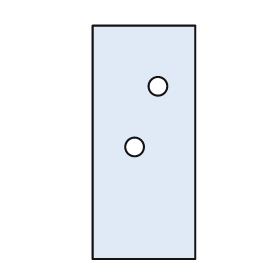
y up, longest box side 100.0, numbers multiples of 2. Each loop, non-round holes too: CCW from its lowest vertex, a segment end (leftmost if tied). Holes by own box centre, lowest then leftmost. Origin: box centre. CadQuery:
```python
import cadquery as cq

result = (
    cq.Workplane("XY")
    .moveTo(-22.0, -50.0)
    .lineTo(22.0, -50.0)
    .lineTo(22.0, 50.0)
    .lineTo(-22.0, 50.0)
    .close()
    .moveTo(-4.0, -2.0)
    .circle(4.0)
    .moveTo(6.0, 24.0)
    .circle(4.0)
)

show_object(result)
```